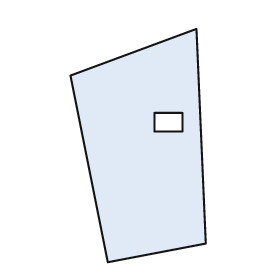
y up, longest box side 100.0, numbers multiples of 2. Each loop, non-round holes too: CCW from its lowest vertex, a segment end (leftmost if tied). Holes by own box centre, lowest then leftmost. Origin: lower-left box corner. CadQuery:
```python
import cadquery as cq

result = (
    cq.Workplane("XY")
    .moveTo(16.0, 0.0)
    .lineTo(58.0, 8.0)
    .lineTo(54.0, 100.0)
    .lineTo(0.0, 80.0)
    .close()
    .moveTo(36.0, 56.0)
    .lineTo(48.0, 56.0)
    .lineTo(48.0, 64.0)
    .lineTo(36.0, 64.0)
    .close()
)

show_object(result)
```